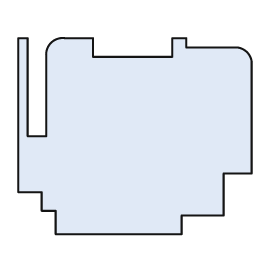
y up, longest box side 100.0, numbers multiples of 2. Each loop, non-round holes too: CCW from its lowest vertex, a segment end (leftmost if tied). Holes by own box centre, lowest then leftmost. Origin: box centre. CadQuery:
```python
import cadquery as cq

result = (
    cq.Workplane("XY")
    .moveTo(-34.0, -42.0)
    .lineTo(20.0, -42.0)
    .lineTo(20.0, -34.0)
    .lineTo(38.0, -34.0)
    .lineTo(38.0, -16.0)
    .lineTo(50.0, -16.0)
    .lineTo(50.0, 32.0)
    .threePointArc((48.0, 36.0), (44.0, 38.0))
    .lineTo(22.0, 38.0)
    .lineTo(22.0, 42.0)
    .lineTo(16.0, 42.0)
    .lineTo(16.0, 34.0)
    .lineTo(-18.0, 34.0)
    .lineTo(-18.0, 42.0)
    .lineTo(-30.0, 42.0)
    .threePointArc((-36.0, 40.0), (-38.0, 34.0))
    .lineTo(-38.0, 0.0)
    .lineTo(-46.0, 0.0)
    .lineTo(-46.0, 42.0)
    .lineTo(-50.0, 42.0)
    .lineTo(-50.0, -24.0)
    .lineTo(-40.0, -24.0)
    .lineTo(-40.0, -32.0)
    .lineTo(-34.0, -32.0)
    .close()
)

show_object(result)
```